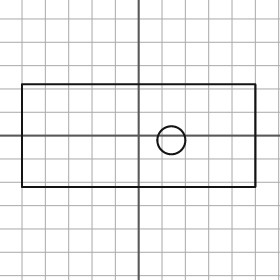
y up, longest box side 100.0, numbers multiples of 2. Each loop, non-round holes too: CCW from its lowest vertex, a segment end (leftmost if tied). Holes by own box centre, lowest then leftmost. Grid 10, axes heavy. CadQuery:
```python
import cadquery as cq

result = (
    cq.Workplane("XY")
    .moveTo(-50.0, -22.0)
    .lineTo(50.0, -22.0)
    .lineTo(50.0, 22.0)
    .lineTo(-50.0, 22.0)
    .close()
    .moveTo(14.0, -2.0)
    .circle(6.0)
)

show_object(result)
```